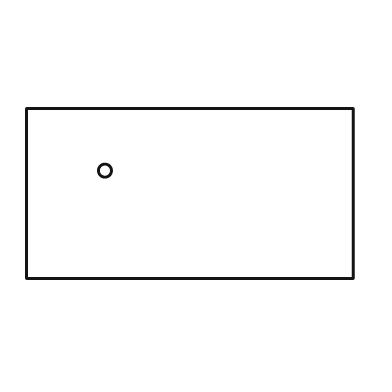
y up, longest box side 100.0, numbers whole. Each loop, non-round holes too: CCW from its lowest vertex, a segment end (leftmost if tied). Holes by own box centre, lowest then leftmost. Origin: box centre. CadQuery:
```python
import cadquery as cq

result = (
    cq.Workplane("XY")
    .moveTo(-50.0, -26.0)
    .lineTo(50.0, -26.0)
    .lineTo(50.0, 26.0)
    .lineTo(-50.0, 26.0)
    .close()
    .moveTo(-26.0, 7.0)
    .circle(2.0)
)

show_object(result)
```